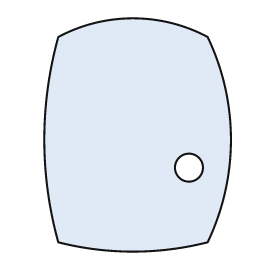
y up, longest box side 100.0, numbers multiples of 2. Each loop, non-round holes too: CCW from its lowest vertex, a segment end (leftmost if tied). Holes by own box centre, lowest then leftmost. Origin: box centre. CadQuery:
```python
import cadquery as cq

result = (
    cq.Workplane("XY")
    .moveTo(-34.0, -46.0)
    .threePointArc((-2.0, -50.0), (30.0, -46.0))
    .threePointArc((40.0, -2.0), (30.0, 42.0))
    .threePointArc((-2.0, 50.0), (-34.0, 42.0))
    .threePointArc((-40.0, -2.0), (-34.0, -46.0))
    .close()
    .moveTo(22.0, -14.0)
    .circle(6.0)
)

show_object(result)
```